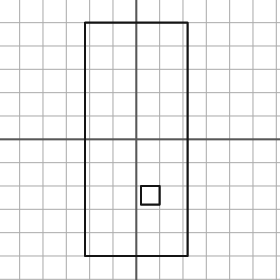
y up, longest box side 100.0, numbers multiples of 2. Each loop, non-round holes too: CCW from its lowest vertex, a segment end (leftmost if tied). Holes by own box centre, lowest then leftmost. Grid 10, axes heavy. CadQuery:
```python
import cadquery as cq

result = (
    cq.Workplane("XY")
    .moveTo(-22.0, -50.0)
    .lineTo(22.0, -50.0)
    .lineTo(22.0, 50.0)
    .lineTo(-22.0, 50.0)
    .close()
    .moveTo(2.0, -28.0)
    .lineTo(10.0, -28.0)
    .lineTo(10.0, -20.0)
    .lineTo(2.0, -20.0)
    .close()
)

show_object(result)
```